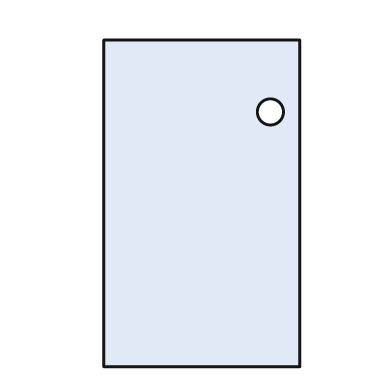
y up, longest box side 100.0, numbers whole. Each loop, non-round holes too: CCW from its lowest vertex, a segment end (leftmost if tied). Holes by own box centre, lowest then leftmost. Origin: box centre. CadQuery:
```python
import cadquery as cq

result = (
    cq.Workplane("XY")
    .moveTo(-30.0, -50.0)
    .lineTo(30.0, -50.0)
    .lineTo(30.0, 50.0)
    .lineTo(-30.0, 50.0)
    .close()
    .moveTo(21.0, 28.0)
    .circle(4.0)
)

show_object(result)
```